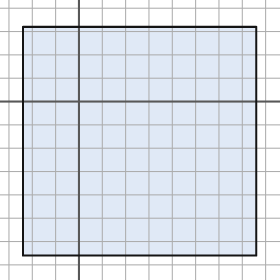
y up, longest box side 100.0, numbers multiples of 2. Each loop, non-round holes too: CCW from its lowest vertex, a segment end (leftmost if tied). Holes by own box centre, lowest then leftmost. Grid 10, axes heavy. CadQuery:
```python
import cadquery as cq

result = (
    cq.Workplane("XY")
    .moveTo(-24.0, -66.0)
    .lineTo(76.0, -66.0)
    .lineTo(76.0, 32.0)
    .lineTo(-24.0, 32.0)
    .close()
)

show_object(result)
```